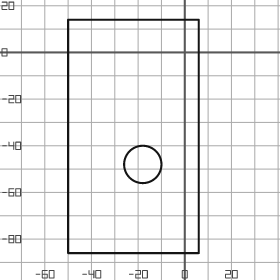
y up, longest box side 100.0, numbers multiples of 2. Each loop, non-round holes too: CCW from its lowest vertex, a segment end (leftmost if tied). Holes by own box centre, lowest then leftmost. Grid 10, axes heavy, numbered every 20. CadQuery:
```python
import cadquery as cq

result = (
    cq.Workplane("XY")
    .moveTo(-50.0, -86.0)
    .lineTo(6.0, -86.0)
    .lineTo(6.0, 14.0)
    .lineTo(-50.0, 14.0)
    .close()
    .moveTo(-18.0, -48.0)
    .circle(8.0)
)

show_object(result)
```